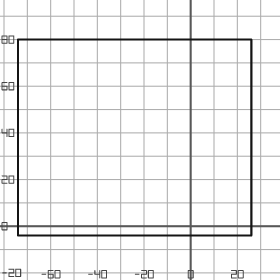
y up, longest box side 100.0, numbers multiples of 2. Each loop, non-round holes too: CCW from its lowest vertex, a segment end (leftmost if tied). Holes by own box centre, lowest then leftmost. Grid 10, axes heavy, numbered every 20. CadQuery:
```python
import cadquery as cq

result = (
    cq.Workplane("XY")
    .moveTo(-74.0, -4.0)
    .lineTo(26.0, -4.0)
    .lineTo(26.0, 80.0)
    .lineTo(-74.0, 80.0)
    .close()
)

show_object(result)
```